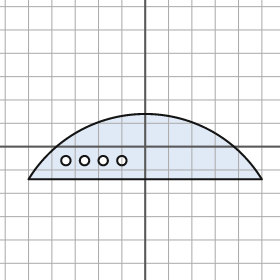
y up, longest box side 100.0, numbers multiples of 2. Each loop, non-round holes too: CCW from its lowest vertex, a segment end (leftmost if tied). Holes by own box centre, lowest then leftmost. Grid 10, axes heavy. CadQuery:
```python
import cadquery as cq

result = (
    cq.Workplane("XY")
    .moveTo(-50.0, -14.0)
    .lineTo(50.0, -14.0)
    .threePointArc((0.0, 14.0), (-50.0, -14.0))
    .close()
    .moveTo(-34.0, -6.0)
    .circle(2.0)
    .moveTo(-26.0, -6.0)
    .circle(2.0)
    .moveTo(-18.0, -6.0)
    .circle(2.0)
    .moveTo(-10.0, -6.0)
    .circle(2.0)
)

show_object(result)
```